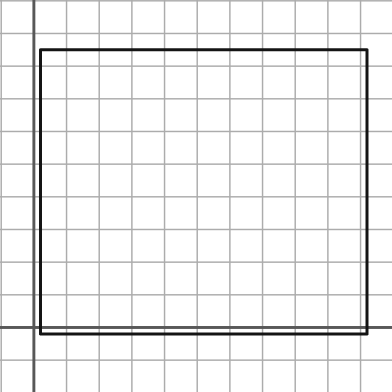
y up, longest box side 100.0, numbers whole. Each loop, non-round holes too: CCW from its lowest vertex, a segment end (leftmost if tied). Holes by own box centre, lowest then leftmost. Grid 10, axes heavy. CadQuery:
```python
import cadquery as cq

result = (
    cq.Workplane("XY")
    .moveTo(2.0, -2.0)
    .lineTo(102.0, -2.0)
    .lineTo(102.0, 85.0)
    .lineTo(2.0, 85.0)
    .close()
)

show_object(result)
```